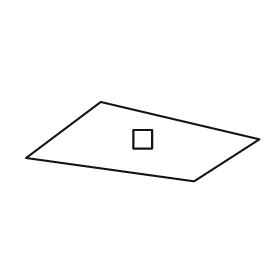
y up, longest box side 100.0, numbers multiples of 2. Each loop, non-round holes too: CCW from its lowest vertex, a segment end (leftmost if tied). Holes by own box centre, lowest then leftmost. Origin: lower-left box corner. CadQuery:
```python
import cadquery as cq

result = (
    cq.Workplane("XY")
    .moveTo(72.0, 0.0)
    .lineTo(100.0, 18.0)
    .lineTo(32.0, 34.0)
    .lineTo(0.0, 10.0)
    .close()
    .moveTo(46.0, 14.0)
    .lineTo(54.0, 14.0)
    .lineTo(54.0, 22.0)
    .lineTo(46.0, 22.0)
    .close()
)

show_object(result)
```